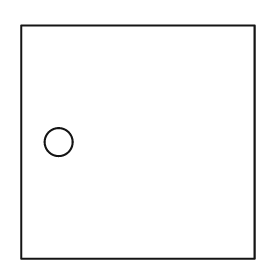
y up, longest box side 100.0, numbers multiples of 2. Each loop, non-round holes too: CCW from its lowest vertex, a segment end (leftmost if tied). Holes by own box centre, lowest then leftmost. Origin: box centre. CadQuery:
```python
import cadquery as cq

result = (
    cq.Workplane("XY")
    .moveTo(-50.0, -50.0)
    .lineTo(50.0, -50.0)
    .lineTo(50.0, 50.0)
    .lineTo(-50.0, 50.0)
    .close()
    .moveTo(-34.0, 0.0)
    .circle(6.0)
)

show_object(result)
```